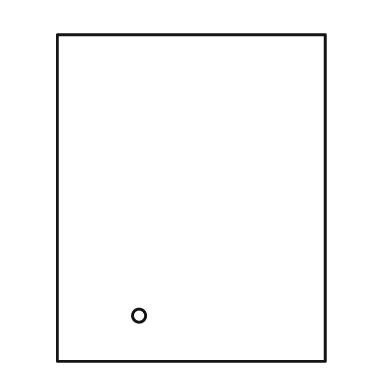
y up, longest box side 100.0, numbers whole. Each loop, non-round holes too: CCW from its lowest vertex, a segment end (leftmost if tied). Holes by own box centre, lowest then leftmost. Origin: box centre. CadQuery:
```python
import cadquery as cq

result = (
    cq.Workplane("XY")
    .moveTo(-41.0, -50.0)
    .lineTo(41.0, -50.0)
    .lineTo(41.0, 50.0)
    .lineTo(-41.0, 50.0)
    .close()
    .moveTo(-16.0, -36.0)
    .circle(2.0)
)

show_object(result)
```